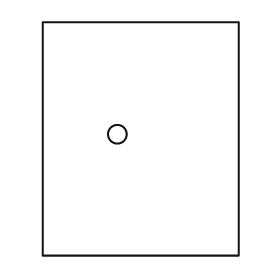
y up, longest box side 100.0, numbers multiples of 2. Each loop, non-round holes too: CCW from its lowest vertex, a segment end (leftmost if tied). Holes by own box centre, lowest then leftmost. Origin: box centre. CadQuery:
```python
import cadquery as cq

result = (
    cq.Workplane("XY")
    .moveTo(-42.0, -50.0)
    .lineTo(42.0, -50.0)
    .lineTo(42.0, 50.0)
    .lineTo(-42.0, 50.0)
    .close()
    .moveTo(-10.0, 2.0)
    .circle(4.0)
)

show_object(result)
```